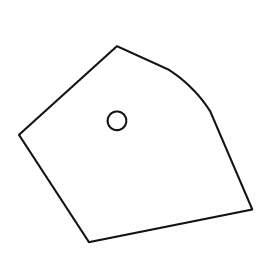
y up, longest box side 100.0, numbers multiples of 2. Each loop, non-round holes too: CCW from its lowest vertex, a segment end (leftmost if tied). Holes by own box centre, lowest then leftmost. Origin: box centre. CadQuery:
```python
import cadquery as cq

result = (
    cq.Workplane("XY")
    .moveTo(-20.0, -42.0)
    .lineTo(50.0, -28.0)
    .lineTo(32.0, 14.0)
    .threePointArc((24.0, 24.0), (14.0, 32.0))
    .lineTo(-8.0, 42.0)
    .lineTo(-50.0, 4.0)
    .close()
    .moveTo(-8.0, 10.0)
    .circle(4.0)
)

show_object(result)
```